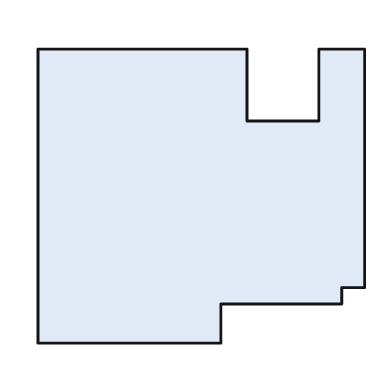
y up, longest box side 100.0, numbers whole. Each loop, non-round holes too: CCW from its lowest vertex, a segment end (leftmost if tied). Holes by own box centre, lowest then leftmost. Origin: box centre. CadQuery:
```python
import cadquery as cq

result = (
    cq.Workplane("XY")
    .moveTo(-50.0, -45.0)
    .lineTo(6.0, -45.0)
    .lineTo(6.0, -33.0)
    .lineTo(43.0, -33.0)
    .lineTo(43.0, -28.0)
    .lineTo(50.0, -28.0)
    .lineTo(50.0, 45.0)
    .lineTo(36.0, 45.0)
    .lineTo(36.0, 23.0)
    .lineTo(14.0, 23.0)
    .lineTo(14.0, 45.0)
    .lineTo(-50.0, 45.0)
    .close()
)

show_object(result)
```